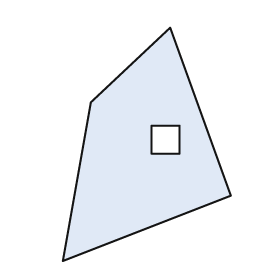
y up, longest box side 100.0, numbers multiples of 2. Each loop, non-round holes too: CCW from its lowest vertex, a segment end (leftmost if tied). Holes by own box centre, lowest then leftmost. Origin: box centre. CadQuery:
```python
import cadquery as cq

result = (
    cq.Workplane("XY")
    .moveTo(-36.0, -50.0)
    .lineTo(36.0, -22.0)
    .lineTo(10.0, 50.0)
    .lineTo(-24.0, 18.0)
    .close()
    .moveTo(2.0, -4.0)
    .lineTo(14.0, -4.0)
    .lineTo(14.0, 8.0)
    .lineTo(2.0, 8.0)
    .close()
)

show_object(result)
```